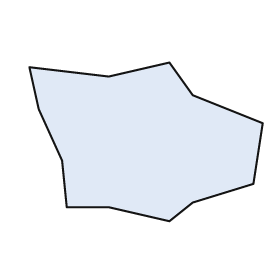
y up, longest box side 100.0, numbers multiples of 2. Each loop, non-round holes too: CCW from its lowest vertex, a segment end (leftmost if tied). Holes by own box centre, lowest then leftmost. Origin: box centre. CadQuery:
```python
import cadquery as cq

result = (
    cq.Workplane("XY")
    .moveTo(10.0, -34.0)
    .lineTo(20.0, -26.0)
    .lineTo(46.0, -18.0)
    .lineTo(50.0, 8.0)
    .lineTo(20.0, 20.0)
    .lineTo(10.0, 34.0)
    .lineTo(-16.0, 28.0)
    .lineTo(-50.0, 32.0)
    .lineTo(-46.0, 14.0)
    .lineTo(-36.0, -8.0)
    .lineTo(-34.0, -28.0)
    .lineTo(-16.0, -28.0)
    .close()
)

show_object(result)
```